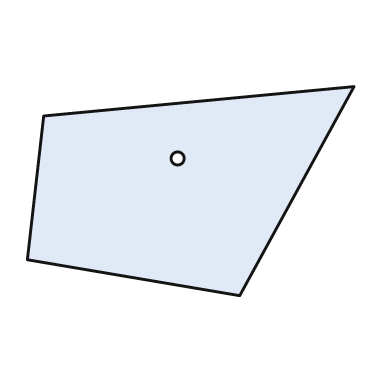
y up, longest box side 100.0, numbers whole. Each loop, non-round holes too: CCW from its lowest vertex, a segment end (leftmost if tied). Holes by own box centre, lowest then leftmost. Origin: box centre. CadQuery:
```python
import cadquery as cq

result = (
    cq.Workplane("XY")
    .moveTo(15.0, -32.0)
    .lineTo(50.0, 32.0)
    .lineTo(-45.0, 23.0)
    .lineTo(-50.0, -21.0)
    .close()
    .moveTo(-4.0, 10.0)
    .circle(2.0)
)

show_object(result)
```